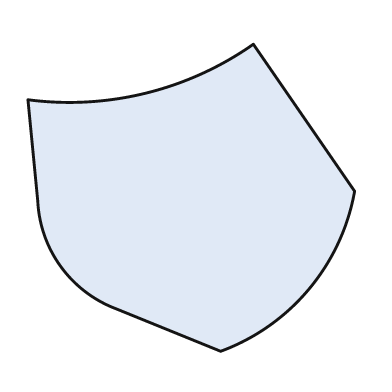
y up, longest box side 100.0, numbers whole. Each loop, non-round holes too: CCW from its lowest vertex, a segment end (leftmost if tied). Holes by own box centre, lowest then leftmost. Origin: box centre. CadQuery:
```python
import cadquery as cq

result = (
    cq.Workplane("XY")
    .moveTo(9.0, -47.0)
    .threePointArc((36.0, -28.0), (50.0, 2.0))
    .lineTo(19.0, 47.0)
    .threePointArc((-14.0, 32.0), (-50.0, 30.0))
    .lineTo(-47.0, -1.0)
    .threePointArc((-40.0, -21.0), (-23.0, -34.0))
    .close()
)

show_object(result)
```